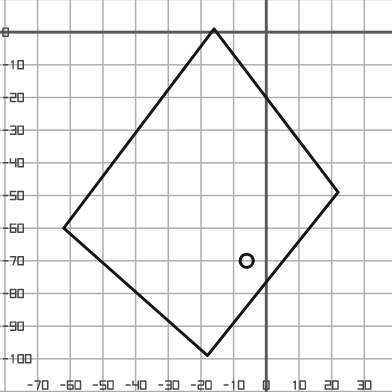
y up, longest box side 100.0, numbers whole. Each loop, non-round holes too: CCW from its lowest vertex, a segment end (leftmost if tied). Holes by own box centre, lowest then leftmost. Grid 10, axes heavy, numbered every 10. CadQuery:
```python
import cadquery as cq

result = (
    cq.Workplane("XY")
    .moveTo(-18.0, -99.0)
    .lineTo(22.0, -49.0)
    .lineTo(-16.0, 1.0)
    .lineTo(-62.0, -60.0)
    .close()
    .moveTo(-6.0, -70.0)
    .circle(2.0)
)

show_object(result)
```